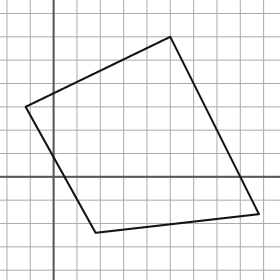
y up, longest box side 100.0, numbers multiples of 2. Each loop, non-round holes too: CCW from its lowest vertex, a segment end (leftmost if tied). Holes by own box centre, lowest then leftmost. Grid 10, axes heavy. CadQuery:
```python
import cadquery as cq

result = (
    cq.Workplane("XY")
    .moveTo(18.0, -24.0)
    .lineTo(88.0, -16.0)
    .lineTo(50.0, 60.0)
    .lineTo(-12.0, 30.0)
    .close()
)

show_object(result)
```